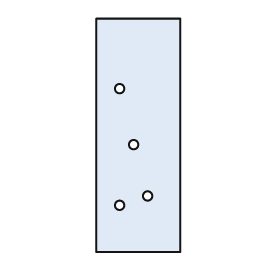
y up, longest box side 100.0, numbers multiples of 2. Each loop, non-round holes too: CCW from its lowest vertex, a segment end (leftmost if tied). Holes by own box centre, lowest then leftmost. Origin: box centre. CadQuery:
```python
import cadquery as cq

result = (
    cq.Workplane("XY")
    .moveTo(-18.0, -50.0)
    .lineTo(18.0, -50.0)
    .lineTo(18.0, 50.0)
    .lineTo(-18.0, 50.0)
    .close()
    .moveTo(-8.0, -30.0)
    .circle(2.0)
    .moveTo(4.0, -26.0)
    .circle(2.0)
    .moveTo(-2.0, -4.0)
    .circle(2.0)
    .moveTo(-8.0, 20.0)
    .circle(2.0)
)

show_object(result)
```